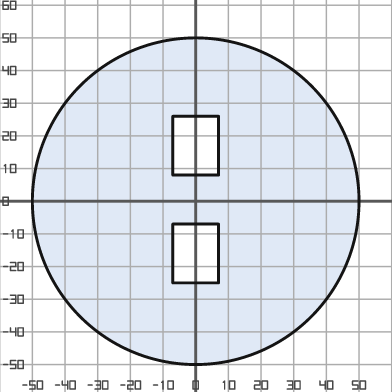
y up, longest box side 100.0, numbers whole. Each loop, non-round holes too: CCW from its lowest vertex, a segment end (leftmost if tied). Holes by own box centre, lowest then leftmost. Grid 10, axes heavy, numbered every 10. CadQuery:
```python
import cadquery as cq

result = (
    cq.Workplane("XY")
    .moveTo(0.0, 0.0)
    .circle(50.0)
    .moveTo(-7.0, -25.0)
    .lineTo(7.0, -25.0)
    .lineTo(7.0, -7.0)
    .lineTo(-7.0, -7.0)
    .close()
    .moveTo(-7.0, 8.0)
    .lineTo(7.0, 8.0)
    .lineTo(7.0, 26.0)
    .lineTo(-7.0, 26.0)
    .close()
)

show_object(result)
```